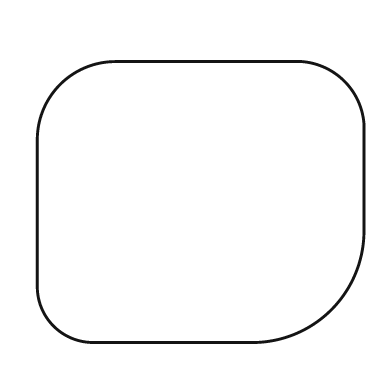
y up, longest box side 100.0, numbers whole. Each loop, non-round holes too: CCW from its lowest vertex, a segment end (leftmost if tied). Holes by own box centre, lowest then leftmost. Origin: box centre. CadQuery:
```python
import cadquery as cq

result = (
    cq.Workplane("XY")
    .moveTo(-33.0, -43.0)
    .lineTo(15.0, -43.0)
    .threePointArc((40.0, -33.0), (50.0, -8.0))
    .lineTo(50.0, 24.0)
    .threePointArc((44.0, 37.0), (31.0, 43.0))
    .lineTo(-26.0, 43.0)
    .threePointArc((-43.0, 36.0), (-50.0, 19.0))
    .lineTo(-50.0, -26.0)
    .threePointArc((-45.0, -38.0), (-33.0, -43.0))
    .close()
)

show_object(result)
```